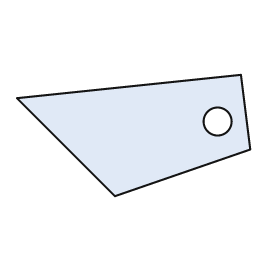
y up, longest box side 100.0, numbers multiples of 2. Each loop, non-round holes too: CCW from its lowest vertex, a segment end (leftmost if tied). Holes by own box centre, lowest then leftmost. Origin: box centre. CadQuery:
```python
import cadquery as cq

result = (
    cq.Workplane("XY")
    .moveTo(-8.0, -26.0)
    .lineTo(50.0, -6.0)
    .lineTo(46.0, 26.0)
    .lineTo(-50.0, 16.0)
    .close()
    .moveTo(36.0, 6.0)
    .circle(6.0)
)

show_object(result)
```